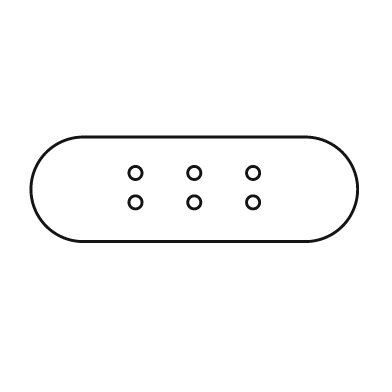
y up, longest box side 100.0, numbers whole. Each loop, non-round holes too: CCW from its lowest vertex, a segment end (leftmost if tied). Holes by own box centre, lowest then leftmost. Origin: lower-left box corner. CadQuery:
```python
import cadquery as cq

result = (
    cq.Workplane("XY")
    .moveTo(16.0, 0.0)
    .lineTo(84.0, 0.0)
    .threePointArc((100.0, 16.0), (84.0, 32.0))
    .lineTo(16.0, 32.0)
    .threePointArc((0.0, 16.0), (16.0, 0.0))
    .close()
    .moveTo(32.0, 12.0)
    .circle(2.0)
    .moveTo(50.0, 12.0)
    .circle(2.0)
    .moveTo(68.0, 12.0)
    .circle(2.0)
    .moveTo(32.0, 21.0)
    .circle(2.0)
    .moveTo(50.0, 21.0)
    .circle(2.0)
    .moveTo(68.0, 21.0)
    .circle(2.0)
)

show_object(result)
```